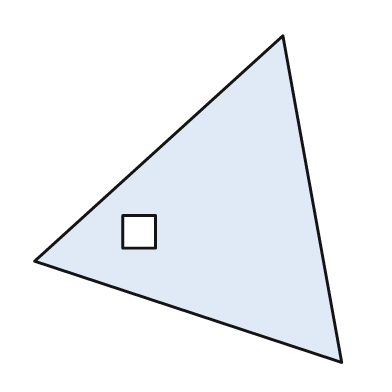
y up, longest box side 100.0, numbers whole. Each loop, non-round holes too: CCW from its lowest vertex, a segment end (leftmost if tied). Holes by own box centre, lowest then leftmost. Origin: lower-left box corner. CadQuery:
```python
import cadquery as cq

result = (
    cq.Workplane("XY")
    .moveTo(94.0, 0.0)
    .lineTo(76.0, 100.0)
    .lineTo(0.0, 31.0)
    .close()
    .moveTo(27.0, 35.0)
    .lineTo(37.0, 35.0)
    .lineTo(37.0, 45.0)
    .lineTo(27.0, 45.0)
    .close()
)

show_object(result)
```